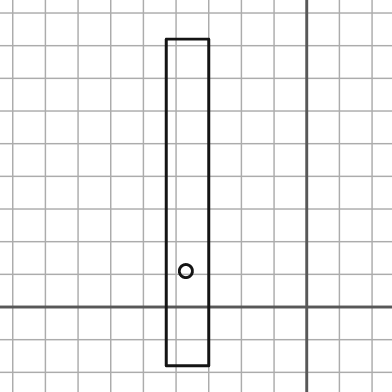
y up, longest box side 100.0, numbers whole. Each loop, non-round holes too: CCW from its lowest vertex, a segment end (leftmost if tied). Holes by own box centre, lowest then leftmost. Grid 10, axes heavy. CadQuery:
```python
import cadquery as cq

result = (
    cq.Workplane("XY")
    .moveTo(-43.0, -18.0)
    .lineTo(-30.0, -18.0)
    .lineTo(-30.0, 82.0)
    .lineTo(-43.0, 82.0)
    .close()
    .moveTo(-37.0, 11.0)
    .circle(2.0)
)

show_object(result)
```